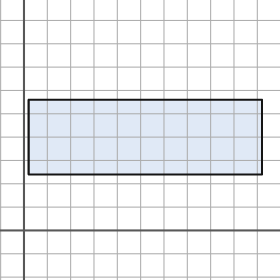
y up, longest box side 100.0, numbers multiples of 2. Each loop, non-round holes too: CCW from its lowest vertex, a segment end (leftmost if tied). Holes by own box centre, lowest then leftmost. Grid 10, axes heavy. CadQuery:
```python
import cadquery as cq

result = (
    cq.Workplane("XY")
    .moveTo(2.0, 24.0)
    .lineTo(102.0, 24.0)
    .lineTo(102.0, 56.0)
    .lineTo(2.0, 56.0)
    .close()
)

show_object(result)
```